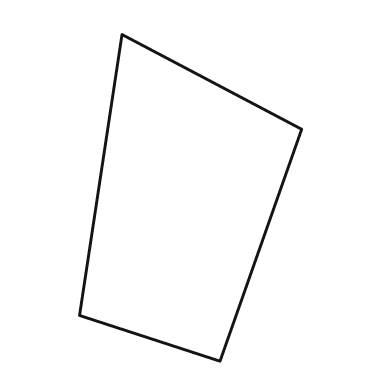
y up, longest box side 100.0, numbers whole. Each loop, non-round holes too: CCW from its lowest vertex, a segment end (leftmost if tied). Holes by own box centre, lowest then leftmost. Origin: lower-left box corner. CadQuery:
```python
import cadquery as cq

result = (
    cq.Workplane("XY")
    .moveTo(43.0, 0.0)
    .lineTo(68.0, 71.0)
    .lineTo(13.0, 100.0)
    .lineTo(0.0, 14.0)
    .close()
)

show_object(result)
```